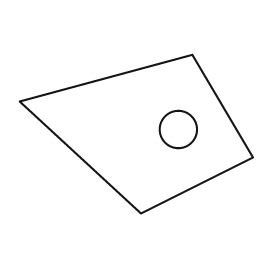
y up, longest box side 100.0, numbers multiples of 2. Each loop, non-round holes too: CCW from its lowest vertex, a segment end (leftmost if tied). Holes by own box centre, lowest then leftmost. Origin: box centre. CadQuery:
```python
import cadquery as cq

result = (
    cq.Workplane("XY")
    .moveTo(2.0, -34.0)
    .lineTo(50.0, -10.0)
    .lineTo(24.0, 34.0)
    .lineTo(-50.0, 14.0)
    .close()
    .moveTo(18.0, 2.0)
    .circle(8.0)
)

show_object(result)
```